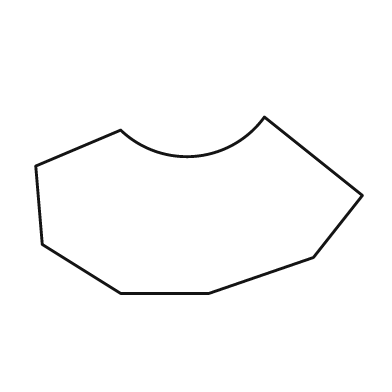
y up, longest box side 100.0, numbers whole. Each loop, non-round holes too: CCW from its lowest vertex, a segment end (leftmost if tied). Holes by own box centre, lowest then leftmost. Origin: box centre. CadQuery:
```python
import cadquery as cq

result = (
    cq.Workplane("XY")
    .moveTo(-24.0, -27.0)
    .lineTo(3.0, -27.0)
    .lineTo(35.0, -16.0)
    .lineTo(50.0, 3.0)
    .lineTo(20.0, 27.0)
    .threePointArc((-1.0, 15.0), (-24.0, 23.0))
    .lineTo(-50.0, 12.0)
    .lineTo(-48.0, -12.0)
    .close()
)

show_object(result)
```